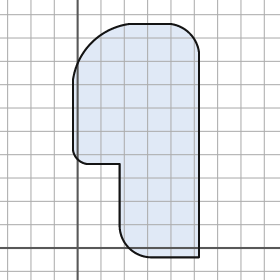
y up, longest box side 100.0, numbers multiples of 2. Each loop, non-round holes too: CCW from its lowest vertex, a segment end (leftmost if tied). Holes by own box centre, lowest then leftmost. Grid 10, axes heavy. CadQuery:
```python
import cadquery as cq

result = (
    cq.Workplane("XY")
    .moveTo(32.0, -4.0)
    .lineTo(52.0, -4.0)
    .lineTo(52.0, 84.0)
    .threePointArc((48.0, 92.0), (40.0, 96.0))
    .lineTo(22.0, 96.0)
    .threePointArc((6.0, 88.0), (-2.0, 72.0))
    .lineTo(-2.0, 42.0)
    .threePointArc((0.0, 38.0), (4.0, 36.0))
    .lineTo(18.0, 36.0)
    .lineTo(18.0, 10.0)
    .threePointArc((22.0, 0.0), (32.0, -4.0))
    .close()
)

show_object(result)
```